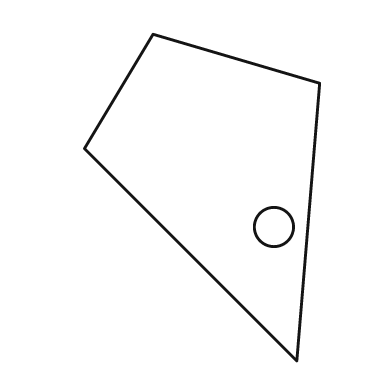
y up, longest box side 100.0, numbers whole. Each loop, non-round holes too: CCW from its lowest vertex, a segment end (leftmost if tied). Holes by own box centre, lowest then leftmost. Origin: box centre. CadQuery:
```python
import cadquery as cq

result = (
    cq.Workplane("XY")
    .moveTo(29.0, -50.0)
    .lineTo(36.0, 35.0)
    .lineTo(-15.0, 50.0)
    .lineTo(-36.0, 15.0)
    .close()
    .moveTo(22.0, -9.0)
    .circle(6.0)
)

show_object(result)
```